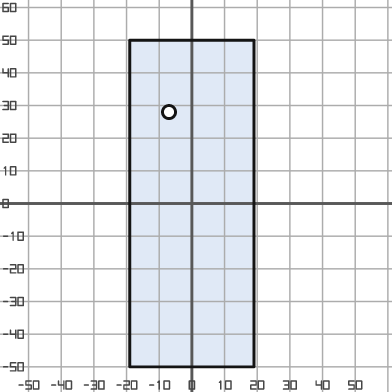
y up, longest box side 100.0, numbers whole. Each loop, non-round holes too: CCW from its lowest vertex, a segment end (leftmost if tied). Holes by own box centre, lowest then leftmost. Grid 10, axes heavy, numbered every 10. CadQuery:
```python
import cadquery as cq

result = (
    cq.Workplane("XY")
    .moveTo(-19.0, -50.0)
    .lineTo(19.0, -50.0)
    .lineTo(19.0, 50.0)
    .lineTo(-19.0, 50.0)
    .close()
    .moveTo(-7.0, 28.0)
    .circle(2.0)
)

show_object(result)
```